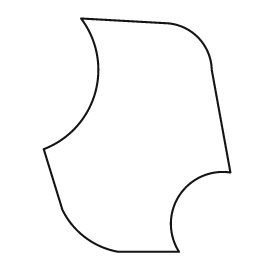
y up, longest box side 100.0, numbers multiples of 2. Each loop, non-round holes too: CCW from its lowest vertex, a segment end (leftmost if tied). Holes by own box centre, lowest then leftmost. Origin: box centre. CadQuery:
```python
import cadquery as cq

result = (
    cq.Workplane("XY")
    .moveTo(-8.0, -50.0)
    .lineTo(18.0, -50.0)
    .threePointArc((18.0, -26.0), (40.0, -16.0))
    .lineTo(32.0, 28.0)
    .threePointArc((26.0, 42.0), (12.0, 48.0))
    .lineTo(-24.0, 50.0)
    .threePointArc((-18.0, 18.0), (-40.0, -6.0))
    .lineTo(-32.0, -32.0)
    .threePointArc((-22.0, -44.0), (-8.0, -50.0))
    .close()
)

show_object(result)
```